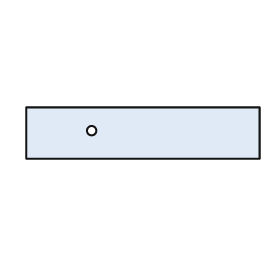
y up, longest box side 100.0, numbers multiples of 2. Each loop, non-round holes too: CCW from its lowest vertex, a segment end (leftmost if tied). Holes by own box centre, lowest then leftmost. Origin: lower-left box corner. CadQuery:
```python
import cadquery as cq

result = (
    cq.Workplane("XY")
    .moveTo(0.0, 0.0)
    .lineTo(100.0, 0.0)
    .lineTo(100.0, 22.0)
    .lineTo(0.0, 22.0)
    .close()
    .moveTo(28.0, 12.0)
    .circle(2.0)
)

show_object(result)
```